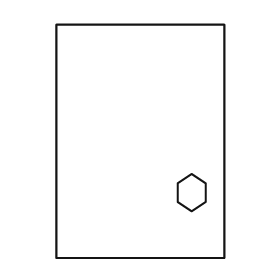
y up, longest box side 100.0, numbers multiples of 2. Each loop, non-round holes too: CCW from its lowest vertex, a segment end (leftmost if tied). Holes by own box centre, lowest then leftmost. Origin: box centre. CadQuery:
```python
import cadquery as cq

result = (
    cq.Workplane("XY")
    .moveTo(-36.0, -50.0)
    .lineTo(36.0, -50.0)
    .lineTo(36.0, 50.0)
    .lineTo(-36.0, 50.0)
    .close()
    .moveTo(22.0, -30.0)
    .lineTo(28.0, -26.0)
    .lineTo(28.0, -18.0)
    .lineTo(22.0, -14.0)
    .lineTo(16.0, -18.0)
    .lineTo(16.0, -26.0)
    .close()
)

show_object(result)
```